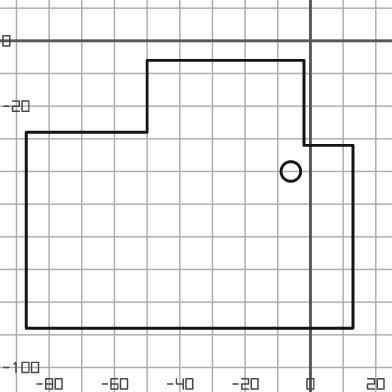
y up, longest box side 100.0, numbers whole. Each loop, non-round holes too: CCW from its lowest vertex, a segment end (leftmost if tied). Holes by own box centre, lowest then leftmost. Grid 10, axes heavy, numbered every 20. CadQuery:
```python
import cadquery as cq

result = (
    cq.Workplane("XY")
    .moveTo(-87.0, -88.0)
    .lineTo(13.0, -88.0)
    .lineTo(13.0, -32.0)
    .lineTo(-2.0, -32.0)
    .lineTo(-2.0, -6.0)
    .lineTo(-50.0, -6.0)
    .lineTo(-50.0, -28.0)
    .lineTo(-87.0, -28.0)
    .close()
    .moveTo(-6.0, -40.0)
    .circle(3.0)
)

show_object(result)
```